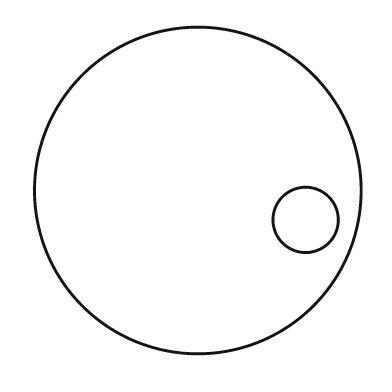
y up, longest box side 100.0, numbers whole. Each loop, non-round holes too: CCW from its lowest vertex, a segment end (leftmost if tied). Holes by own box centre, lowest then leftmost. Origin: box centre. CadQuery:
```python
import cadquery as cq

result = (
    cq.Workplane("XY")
    .moveTo(0.0, 0.0)
    .circle(50.0)
    .moveTo(33.0, -9.0)
    .circle(10.0)
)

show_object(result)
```